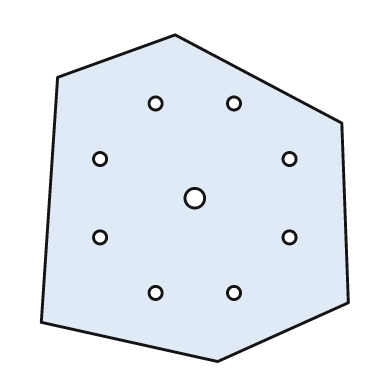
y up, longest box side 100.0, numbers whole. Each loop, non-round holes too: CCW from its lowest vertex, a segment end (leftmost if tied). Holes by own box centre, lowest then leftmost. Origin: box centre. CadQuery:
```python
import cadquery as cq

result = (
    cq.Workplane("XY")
    .moveTo(7.0, -50.0)
    .lineTo(47.0, -32.0)
    .lineTo(45.0, 23.0)
    .lineTo(-6.0, 50.0)
    .lineTo(-42.0, 37.0)
    .lineTo(-47.0, -38.0)
    .close()
    .moveTo(-12.0, -29.0)
    .circle(2.0)
    .moveTo(12.0, -29.0)
    .circle(2.0)
    .moveTo(-29.0, -12.0)
    .circle(2.0)
    .moveTo(29.0, -12.0)
    .circle(2.0)
    .moveTo(0.0, 0.0)
    .circle(3.0)
    .moveTo(-29.0, 12.0)
    .circle(2.0)
    .moveTo(29.0, 12.0)
    .circle(2.0)
    .moveTo(-12.0, 29.0)
    .circle(2.0)
    .moveTo(12.0, 29.0)
    .circle(2.0)
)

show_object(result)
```